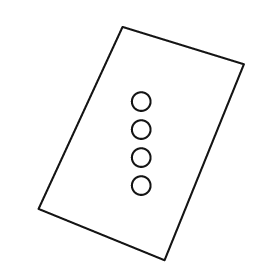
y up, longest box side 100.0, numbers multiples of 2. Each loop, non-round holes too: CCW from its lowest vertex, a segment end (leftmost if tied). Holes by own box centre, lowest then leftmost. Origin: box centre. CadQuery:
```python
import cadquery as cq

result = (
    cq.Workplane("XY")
    .moveTo(10.0, -50.0)
    .lineTo(44.0, 34.0)
    .lineTo(-8.0, 50.0)
    .lineTo(-44.0, -28.0)
    .close()
    .moveTo(0.0, -18.0)
    .circle(4.0)
    .moveTo(0.0, -6.0)
    .circle(4.0)
    .moveTo(0.0, 6.0)
    .circle(4.0)
    .moveTo(0.0, 18.0)
    .circle(4.0)
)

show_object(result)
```